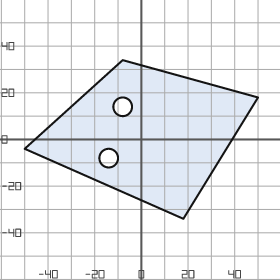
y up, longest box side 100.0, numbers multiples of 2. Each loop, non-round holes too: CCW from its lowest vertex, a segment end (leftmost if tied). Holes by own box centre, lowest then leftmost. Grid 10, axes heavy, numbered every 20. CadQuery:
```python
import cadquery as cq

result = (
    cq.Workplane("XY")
    .moveTo(18.0, -34.0)
    .lineTo(50.0, 18.0)
    .lineTo(-8.0, 34.0)
    .lineTo(-50.0, -4.0)
    .close()
    .moveTo(-14.0, -8.0)
    .circle(4.0)
    .moveTo(-8.0, 14.0)
    .circle(4.0)
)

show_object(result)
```